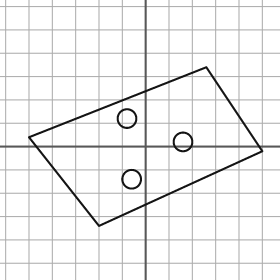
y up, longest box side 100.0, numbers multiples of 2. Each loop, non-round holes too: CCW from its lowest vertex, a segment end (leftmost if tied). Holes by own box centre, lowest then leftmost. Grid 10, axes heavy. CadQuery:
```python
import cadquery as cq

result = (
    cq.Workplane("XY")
    .moveTo(-20.0, -34.0)
    .lineTo(50.0, -2.0)
    .lineTo(26.0, 34.0)
    .lineTo(-50.0, 4.0)
    .close()
    .moveTo(-6.0, -14.0)
    .circle(4.0)
    .moveTo(16.0, 2.0)
    .circle(4.0)
    .moveTo(-8.0, 12.0)
    .circle(4.0)
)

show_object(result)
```